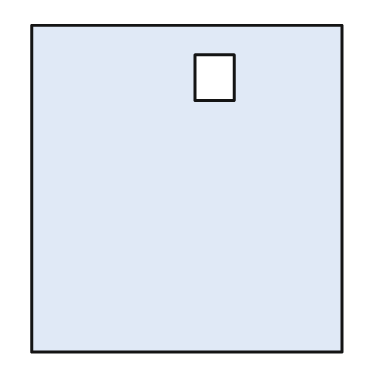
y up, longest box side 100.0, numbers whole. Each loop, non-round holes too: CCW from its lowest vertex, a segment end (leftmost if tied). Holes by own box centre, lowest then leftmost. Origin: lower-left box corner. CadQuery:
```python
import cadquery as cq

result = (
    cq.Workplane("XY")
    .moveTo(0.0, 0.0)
    .lineTo(95.0, 0.0)
    .lineTo(95.0, 100.0)
    .lineTo(0.0, 100.0)
    .close()
    .moveTo(50.0, 77.0)
    .lineTo(62.0, 77.0)
    .lineTo(62.0, 91.0)
    .lineTo(50.0, 91.0)
    .close()
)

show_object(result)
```